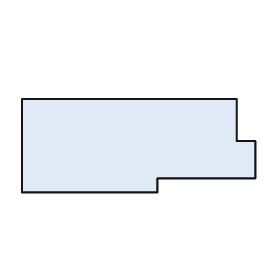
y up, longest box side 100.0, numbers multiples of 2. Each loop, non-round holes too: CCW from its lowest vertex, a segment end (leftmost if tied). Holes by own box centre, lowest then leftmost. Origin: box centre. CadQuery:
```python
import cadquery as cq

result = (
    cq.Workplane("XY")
    .moveTo(-50.0, -20.0)
    .lineTo(8.0, -20.0)
    .lineTo(8.0, -14.0)
    .lineTo(50.0, -14.0)
    .lineTo(50.0, 2.0)
    .lineTo(42.0, 2.0)
    .lineTo(42.0, 20.0)
    .lineTo(-50.0, 20.0)
    .close()
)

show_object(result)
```